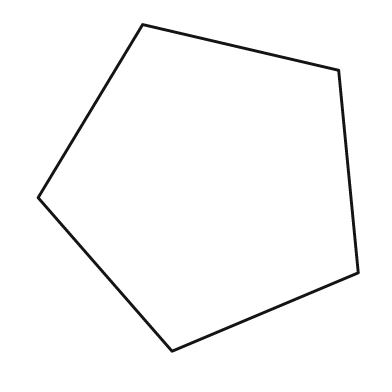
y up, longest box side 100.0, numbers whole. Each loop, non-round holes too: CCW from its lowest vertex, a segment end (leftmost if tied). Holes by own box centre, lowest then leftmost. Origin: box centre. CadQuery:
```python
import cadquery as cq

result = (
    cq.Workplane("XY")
    .moveTo(-8.0, -50.0)
    .lineTo(49.0, -26.0)
    .lineTo(43.0, 36.0)
    .lineTo(-17.0, 50.0)
    .lineTo(-49.0, -3.0)
    .close()
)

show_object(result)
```